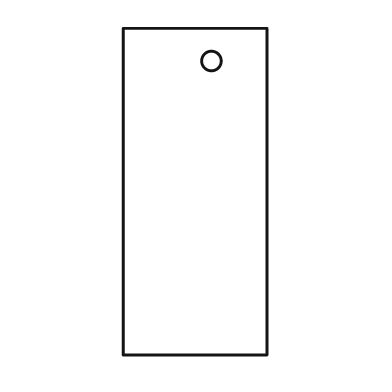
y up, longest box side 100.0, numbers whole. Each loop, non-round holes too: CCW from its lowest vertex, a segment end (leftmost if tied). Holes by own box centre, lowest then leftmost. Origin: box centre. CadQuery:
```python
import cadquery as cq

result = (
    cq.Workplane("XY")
    .moveTo(-22.0, -50.0)
    .lineTo(22.0, -50.0)
    .lineTo(22.0, 50.0)
    .lineTo(-22.0, 50.0)
    .close()
    .moveTo(5.0, 40.0)
    .circle(3.0)
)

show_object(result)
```